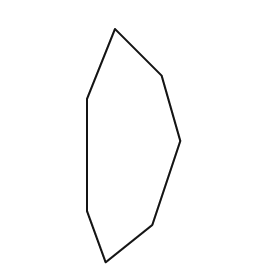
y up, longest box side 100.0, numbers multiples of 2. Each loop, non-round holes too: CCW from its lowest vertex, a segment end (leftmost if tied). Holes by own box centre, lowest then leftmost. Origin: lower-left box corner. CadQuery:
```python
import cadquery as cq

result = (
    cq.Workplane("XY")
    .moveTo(8.0, 0.0)
    .lineTo(28.0, 16.0)
    .lineTo(40.0, 52.0)
    .lineTo(32.0, 80.0)
    .lineTo(12.0, 100.0)
    .lineTo(0.0, 70.0)
    .lineTo(0.0, 22.0)
    .close()
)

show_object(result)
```